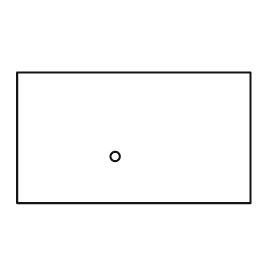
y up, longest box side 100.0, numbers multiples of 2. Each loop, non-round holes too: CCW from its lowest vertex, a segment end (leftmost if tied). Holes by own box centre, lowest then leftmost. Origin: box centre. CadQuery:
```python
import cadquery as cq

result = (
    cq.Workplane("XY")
    .moveTo(-50.0, -28.0)
    .lineTo(50.0, -28.0)
    .lineTo(50.0, 28.0)
    .lineTo(-50.0, 28.0)
    .close()
    .moveTo(-8.0, -8.0)
    .circle(2.0)
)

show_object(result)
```